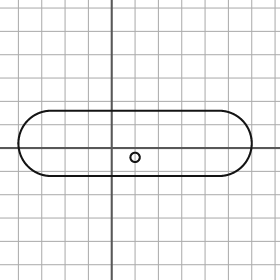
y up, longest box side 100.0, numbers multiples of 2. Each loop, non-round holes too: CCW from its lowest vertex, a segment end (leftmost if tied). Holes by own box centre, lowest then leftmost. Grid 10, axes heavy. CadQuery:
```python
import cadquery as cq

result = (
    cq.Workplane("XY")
    .moveTo(-26.0, -12.0)
    .lineTo(46.0, -12.0)
    .threePointArc((60.0, 2.0), (46.0, 16.0))
    .lineTo(-26.0, 16.0)
    .threePointArc((-40.0, 2.0), (-26.0, -12.0))
    .close()
    .moveTo(10.0, -4.0)
    .circle(2.0)
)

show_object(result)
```